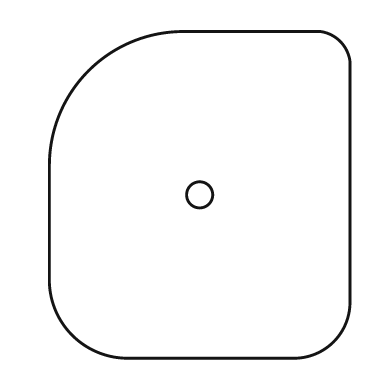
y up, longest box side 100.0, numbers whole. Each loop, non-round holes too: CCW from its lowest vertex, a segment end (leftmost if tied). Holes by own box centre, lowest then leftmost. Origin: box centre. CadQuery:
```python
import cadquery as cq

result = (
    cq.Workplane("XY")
    .moveTo(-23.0, -50.0)
    .lineTo(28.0, -50.0)
    .threePointArc((41.0, -45.0), (46.0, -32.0))
    .lineTo(46.0, 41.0)
    .threePointArc((43.0, 47.0), (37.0, 50.0))
    .lineTo(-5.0, 50.0)
    .threePointArc((-34.0, 38.0), (-46.0, 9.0))
    .lineTo(-46.0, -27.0)
    .threePointArc((-39.0, -43.0), (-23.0, -50.0))
    .close()
    .moveTo(0.0, 0.0)
    .circle(4.0)
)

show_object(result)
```